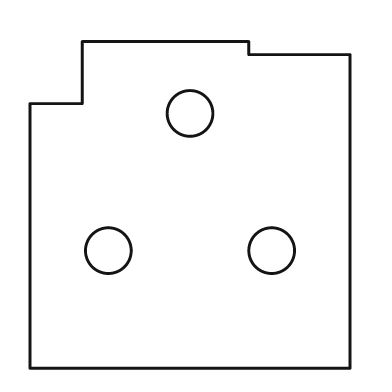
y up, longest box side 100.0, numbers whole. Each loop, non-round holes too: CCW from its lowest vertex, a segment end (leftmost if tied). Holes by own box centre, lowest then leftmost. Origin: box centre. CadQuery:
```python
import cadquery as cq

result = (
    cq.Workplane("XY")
    .moveTo(-49.0, -50.0)
    .lineTo(49.0, -50.0)
    .lineTo(49.0, 46.0)
    .lineTo(18.0, 46.0)
    .lineTo(18.0, 50.0)
    .lineTo(-33.0, 50.0)
    .lineTo(-33.0, 31.0)
    .lineTo(-49.0, 31.0)
    .close()
    .moveTo(-25.0, -14.0)
    .circle(7.0)
    .moveTo(25.0, -14.0)
    .circle(7.0)
    .moveTo(0.0, 28.0)
    .circle(7.0)
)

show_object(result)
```